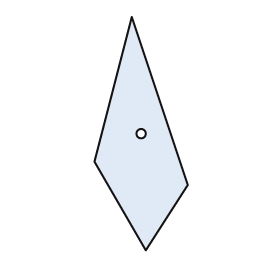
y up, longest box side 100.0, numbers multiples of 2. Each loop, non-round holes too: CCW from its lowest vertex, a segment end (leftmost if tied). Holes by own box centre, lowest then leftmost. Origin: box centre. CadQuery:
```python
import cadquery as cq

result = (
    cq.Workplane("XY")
    .moveTo(2.0, -50.0)
    .lineTo(20.0, -22.0)
    .lineTo(-4.0, 50.0)
    .lineTo(-20.0, -12.0)
    .close()
    .moveTo(0.0, 0.0)
    .circle(2.0)
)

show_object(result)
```